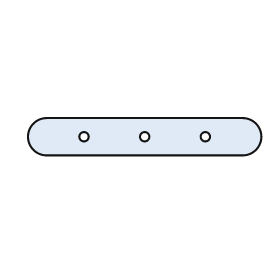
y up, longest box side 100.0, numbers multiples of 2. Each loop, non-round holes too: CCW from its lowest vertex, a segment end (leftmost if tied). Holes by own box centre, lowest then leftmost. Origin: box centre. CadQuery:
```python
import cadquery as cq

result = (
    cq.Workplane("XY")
    .moveTo(-42.0, -8.0)
    .lineTo(42.0, -8.0)
    .threePointArc((50.0, 0.0), (42.0, 8.0))
    .lineTo(-42.0, 8.0)
    .threePointArc((-50.0, 0.0), (-42.0, -8.0))
    .close()
    .moveTo(-26.0, 0.0)
    .circle(2.0)
    .moveTo(0.0, 0.0)
    .circle(2.0)
    .moveTo(26.0, 0.0)
    .circle(2.0)
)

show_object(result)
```